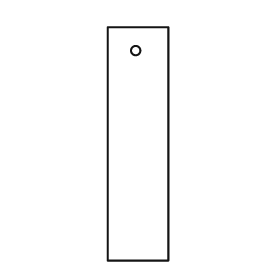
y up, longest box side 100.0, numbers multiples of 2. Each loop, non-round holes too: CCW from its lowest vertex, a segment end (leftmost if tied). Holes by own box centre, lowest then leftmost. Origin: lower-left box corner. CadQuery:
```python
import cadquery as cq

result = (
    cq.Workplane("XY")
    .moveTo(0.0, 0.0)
    .lineTo(26.0, 0.0)
    .lineTo(26.0, 100.0)
    .lineTo(0.0, 100.0)
    .close()
    .moveTo(12.0, 90.0)
    .circle(2.0)
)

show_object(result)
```